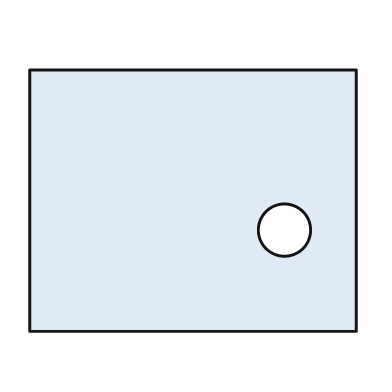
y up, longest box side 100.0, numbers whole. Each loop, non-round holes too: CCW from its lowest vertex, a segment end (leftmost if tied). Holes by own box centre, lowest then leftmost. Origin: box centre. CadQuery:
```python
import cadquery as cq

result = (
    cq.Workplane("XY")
    .moveTo(-50.0, -40.0)
    .lineTo(50.0, -40.0)
    .lineTo(50.0, 40.0)
    .lineTo(-50.0, 40.0)
    .close()
    .moveTo(28.0, -9.0)
    .circle(8.0)
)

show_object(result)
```